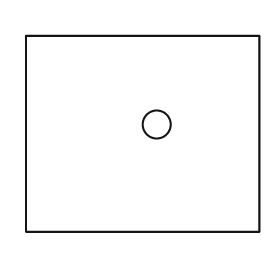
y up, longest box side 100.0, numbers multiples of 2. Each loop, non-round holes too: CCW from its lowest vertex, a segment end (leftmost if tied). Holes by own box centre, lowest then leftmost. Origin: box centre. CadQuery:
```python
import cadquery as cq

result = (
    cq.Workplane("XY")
    .moveTo(-50.0, -42.0)
    .lineTo(50.0, -42.0)
    .lineTo(50.0, 42.0)
    .lineTo(-50.0, 42.0)
    .close()
    .moveTo(6.0, 4.0)
    .circle(6.0)
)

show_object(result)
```